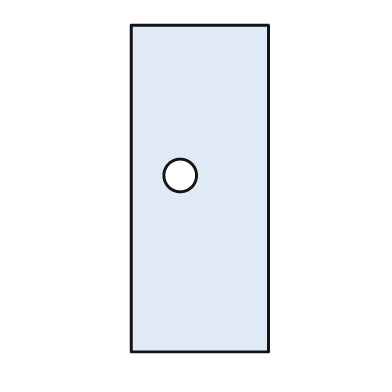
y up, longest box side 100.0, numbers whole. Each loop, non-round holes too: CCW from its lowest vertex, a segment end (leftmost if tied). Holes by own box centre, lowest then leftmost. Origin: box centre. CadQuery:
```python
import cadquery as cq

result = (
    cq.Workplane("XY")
    .moveTo(-21.0, -50.0)
    .lineTo(21.0, -50.0)
    .lineTo(21.0, 50.0)
    .lineTo(-21.0, 50.0)
    .close()
    .moveTo(-6.0, 4.0)
    .circle(5.0)
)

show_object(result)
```